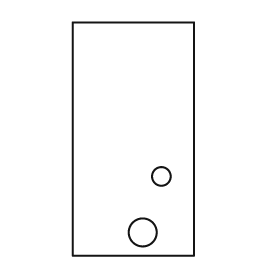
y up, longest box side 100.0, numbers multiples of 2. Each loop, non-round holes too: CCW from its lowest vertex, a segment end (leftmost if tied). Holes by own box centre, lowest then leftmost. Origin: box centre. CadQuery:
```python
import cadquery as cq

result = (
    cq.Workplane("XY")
    .moveTo(-26.0, -50.0)
    .lineTo(26.0, -50.0)
    .lineTo(26.0, 50.0)
    .lineTo(-26.0, 50.0)
    .close()
    .moveTo(4.0, -40.0)
    .circle(6.0)
    .moveTo(12.0, -16.0)
    .circle(4.0)
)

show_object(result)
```